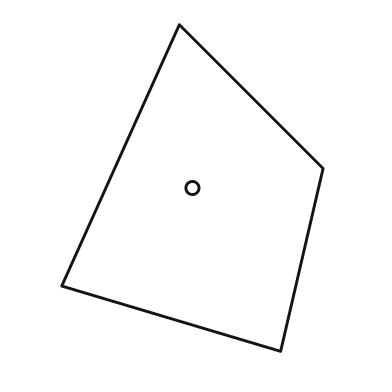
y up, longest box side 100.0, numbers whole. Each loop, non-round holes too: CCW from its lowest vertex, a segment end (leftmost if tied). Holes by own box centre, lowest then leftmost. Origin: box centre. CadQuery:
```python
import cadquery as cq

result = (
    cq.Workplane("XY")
    .moveTo(27.0, -50.0)
    .lineTo(40.0, 6.0)
    .lineTo(-4.0, 50.0)
    .lineTo(-40.0, -30.0)
    .close()
    .moveTo(0.0, 0.0)
    .circle(2.0)
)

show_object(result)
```